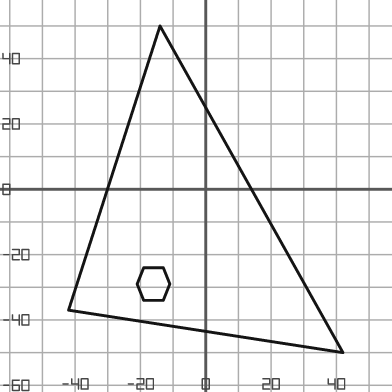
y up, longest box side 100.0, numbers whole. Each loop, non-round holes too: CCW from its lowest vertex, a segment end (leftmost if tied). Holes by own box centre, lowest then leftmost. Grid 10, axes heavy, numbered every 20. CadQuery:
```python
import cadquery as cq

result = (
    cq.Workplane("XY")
    .moveTo(42.0, -50.0)
    .lineTo(-14.0, 50.0)
    .lineTo(-42.0, -37.0)
    .close()
    .moveTo(-19.0, -34.0)
    .lineTo(-13.0, -34.0)
    .lineTo(-11.0, -29.0)
    .lineTo(-13.0, -24.0)
    .lineTo(-19.0, -24.0)
    .lineTo(-21.0, -29.0)
    .close()
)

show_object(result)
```